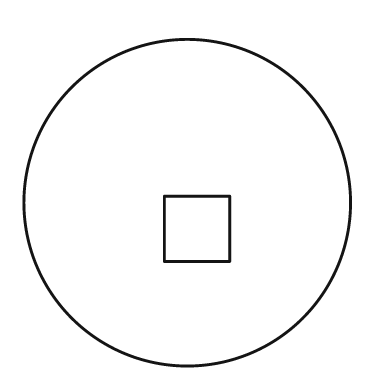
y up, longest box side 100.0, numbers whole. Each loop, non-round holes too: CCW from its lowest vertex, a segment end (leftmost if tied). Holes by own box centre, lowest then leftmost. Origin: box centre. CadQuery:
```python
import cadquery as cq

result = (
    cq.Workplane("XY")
    .moveTo(0.0, 0.0)
    .circle(50.0)
    .moveTo(-7.0, -18.0)
    .lineTo(13.0, -18.0)
    .lineTo(13.0, 2.0)
    .lineTo(-7.0, 2.0)
    .close()
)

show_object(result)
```